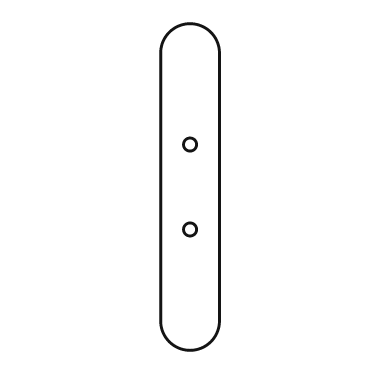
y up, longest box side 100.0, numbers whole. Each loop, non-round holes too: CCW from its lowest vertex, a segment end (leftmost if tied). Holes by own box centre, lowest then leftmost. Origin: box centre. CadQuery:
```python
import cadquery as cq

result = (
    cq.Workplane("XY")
    .moveTo(-9.0, -41.0)
    .threePointArc((0.0, -50.0), (9.0, -41.0))
    .lineTo(9.0, 41.0)
    .threePointArc((0.0, 50.0), (-9.0, 41.0))
    .close()
    .moveTo(0.0, -13.0)
    .circle(2.0)
    .moveTo(0.0, 13.0)
    .circle(2.0)
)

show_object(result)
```